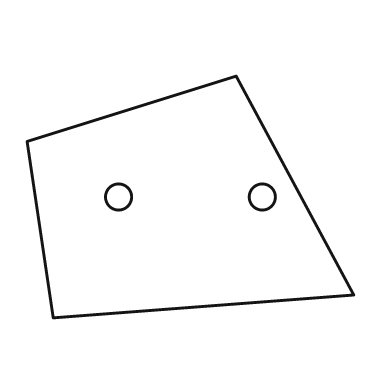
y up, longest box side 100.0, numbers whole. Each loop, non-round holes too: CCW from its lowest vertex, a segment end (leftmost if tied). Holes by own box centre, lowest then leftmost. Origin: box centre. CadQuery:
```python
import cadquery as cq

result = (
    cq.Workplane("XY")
    .moveTo(-42.0, -37.0)
    .lineTo(50.0, -30.0)
    .lineTo(14.0, 37.0)
    .lineTo(-50.0, 17.0)
    .close()
    .moveTo(-22.0, 0.0)
    .circle(4.0)
    .moveTo(22.0, 0.0)
    .circle(4.0)
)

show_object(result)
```